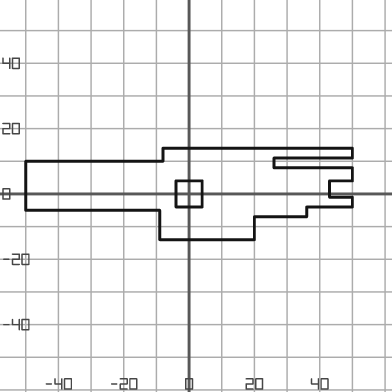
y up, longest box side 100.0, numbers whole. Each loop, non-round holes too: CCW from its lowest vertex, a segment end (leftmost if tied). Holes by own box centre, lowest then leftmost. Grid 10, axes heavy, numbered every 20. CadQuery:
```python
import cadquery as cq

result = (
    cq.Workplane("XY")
    .moveTo(-9.0, -14.0)
    .lineTo(20.0, -14.0)
    .lineTo(20.0, -7.0)
    .lineTo(36.0, -7.0)
    .lineTo(36.0, -4.0)
    .lineTo(50.0, -4.0)
    .lineTo(50.0, -1.0)
    .lineTo(43.0, -1.0)
    .lineTo(43.0, 4.0)
    .lineTo(50.0, 4.0)
    .lineTo(50.0, 8.0)
    .lineTo(26.0, 8.0)
    .lineTo(26.0, 11.0)
    .lineTo(50.0, 11.0)
    .lineTo(50.0, 14.0)
    .lineTo(-8.0, 14.0)
    .lineTo(-8.0, 10.0)
    .lineTo(-50.0, 10.0)
    .lineTo(-50.0, -5.0)
    .lineTo(-9.0, -5.0)
    .close()
    .moveTo(-4.0, -4.0)
    .lineTo(4.0, -4.0)
    .lineTo(4.0, 4.0)
    .lineTo(-4.0, 4.0)
    .close()
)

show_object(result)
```